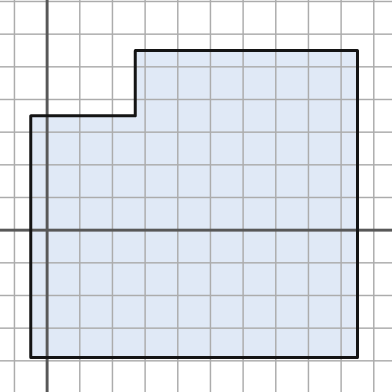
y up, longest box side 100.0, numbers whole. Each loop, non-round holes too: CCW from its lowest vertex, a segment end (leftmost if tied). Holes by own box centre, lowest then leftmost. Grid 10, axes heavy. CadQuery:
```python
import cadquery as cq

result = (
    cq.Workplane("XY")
    .moveTo(-5.0, -39.0)
    .lineTo(95.0, -39.0)
    .lineTo(95.0, 55.0)
    .lineTo(27.0, 55.0)
    .lineTo(27.0, 35.0)
    .lineTo(-5.0, 35.0)
    .close()
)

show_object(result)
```